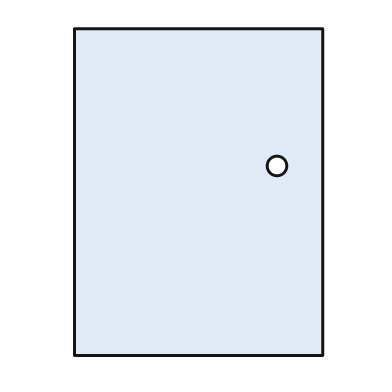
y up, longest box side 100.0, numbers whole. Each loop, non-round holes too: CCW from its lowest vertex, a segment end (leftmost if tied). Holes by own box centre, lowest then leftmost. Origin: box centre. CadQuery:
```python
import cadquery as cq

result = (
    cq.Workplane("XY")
    .moveTo(-38.0, -50.0)
    .lineTo(38.0, -50.0)
    .lineTo(38.0, 50.0)
    .lineTo(-38.0, 50.0)
    .close()
    .moveTo(24.0, 8.0)
    .circle(3.0)
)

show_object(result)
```